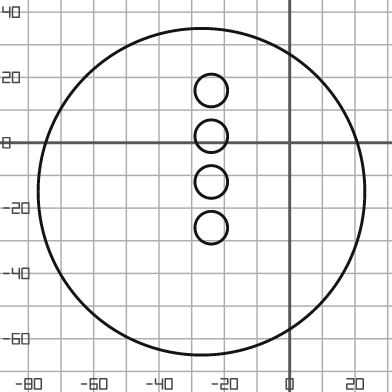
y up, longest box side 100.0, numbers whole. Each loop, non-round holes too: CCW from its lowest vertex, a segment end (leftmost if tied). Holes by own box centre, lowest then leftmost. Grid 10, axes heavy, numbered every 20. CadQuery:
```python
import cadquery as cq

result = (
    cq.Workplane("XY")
    .moveTo(-27.0, -15.0)
    .circle(50.0)
    .moveTo(-24.0, -26.0)
    .circle(5.0)
    .moveTo(-24.0, -12.0)
    .circle(5.0)
    .moveTo(-24.0, 2.0)
    .circle(5.0)
    .moveTo(-24.0, 16.0)
    .circle(5.0)
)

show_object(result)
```